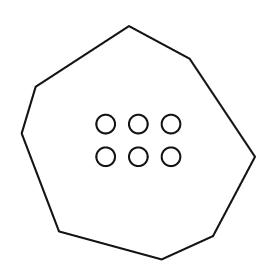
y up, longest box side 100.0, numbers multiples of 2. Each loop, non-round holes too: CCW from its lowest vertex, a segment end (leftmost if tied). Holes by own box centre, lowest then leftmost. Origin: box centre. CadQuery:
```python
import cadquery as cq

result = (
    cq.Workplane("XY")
    .moveTo(10.0, -50.0)
    .lineTo(32.0, -40.0)
    .lineTo(50.0, -6.0)
    .lineTo(22.0, 36.0)
    .lineTo(-4.0, 50.0)
    .lineTo(-44.0, 24.0)
    .lineTo(-50.0, 4.0)
    .lineTo(-34.0, -38.0)
    .close()
    .moveTo(-14.0, -6.0)
    .circle(4.0)
    .moveTo(0.0, -6.0)
    .circle(4.0)
    .moveTo(14.0, -6.0)
    .circle(4.0)
    .moveTo(-14.0, 8.0)
    .circle(4.0)
    .moveTo(0.0, 8.0)
    .circle(4.0)
    .moveTo(14.0, 8.0)
    .circle(4.0)
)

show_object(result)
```